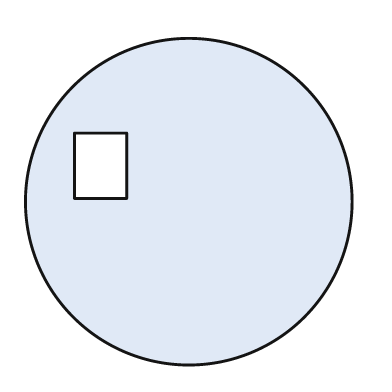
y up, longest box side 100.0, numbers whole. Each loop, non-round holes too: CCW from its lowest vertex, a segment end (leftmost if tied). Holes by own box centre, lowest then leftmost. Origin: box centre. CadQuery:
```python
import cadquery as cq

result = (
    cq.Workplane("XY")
    .moveTo(0.0, 0.0)
    .circle(50.0)
    .moveTo(-35.0, 1.0)
    .lineTo(-19.0, 1.0)
    .lineTo(-19.0, 21.0)
    .lineTo(-35.0, 21.0)
    .close()
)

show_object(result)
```